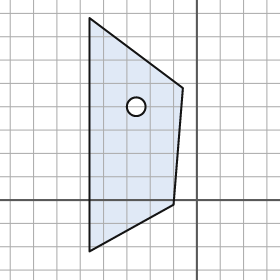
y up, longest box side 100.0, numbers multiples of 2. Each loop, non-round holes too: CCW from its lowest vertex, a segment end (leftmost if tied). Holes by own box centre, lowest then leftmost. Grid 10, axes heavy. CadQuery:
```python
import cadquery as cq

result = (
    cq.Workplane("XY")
    .moveTo(-46.0, -22.0)
    .lineTo(-10.0, -2.0)
    .lineTo(-6.0, 48.0)
    .lineTo(-46.0, 78.0)
    .close()
    .moveTo(-26.0, 40.0)
    .circle(4.0)
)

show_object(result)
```